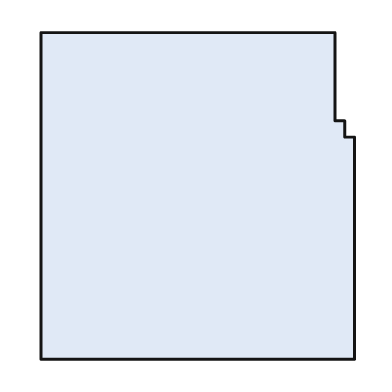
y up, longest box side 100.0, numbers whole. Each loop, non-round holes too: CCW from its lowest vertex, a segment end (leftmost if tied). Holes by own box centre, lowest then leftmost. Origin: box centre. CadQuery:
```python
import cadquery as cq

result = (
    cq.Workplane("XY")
    .moveTo(-48.0, -50.0)
    .lineTo(48.0, -50.0)
    .lineTo(48.0, 18.0)
    .lineTo(45.0, 18.0)
    .lineTo(45.0, 23.0)
    .lineTo(42.0, 23.0)
    .lineTo(42.0, 50.0)
    .lineTo(-48.0, 50.0)
    .close()
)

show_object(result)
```